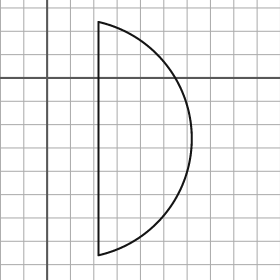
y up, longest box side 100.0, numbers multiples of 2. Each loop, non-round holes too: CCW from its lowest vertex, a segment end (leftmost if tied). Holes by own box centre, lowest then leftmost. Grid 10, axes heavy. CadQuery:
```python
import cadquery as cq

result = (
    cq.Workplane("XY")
    .moveTo(22.0, -76.0)
    .threePointArc((62.0, -26.0), (22.0, 24.0))
    .close()
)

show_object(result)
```